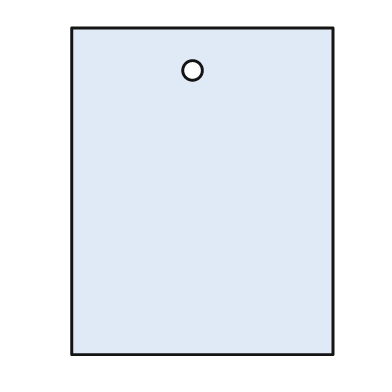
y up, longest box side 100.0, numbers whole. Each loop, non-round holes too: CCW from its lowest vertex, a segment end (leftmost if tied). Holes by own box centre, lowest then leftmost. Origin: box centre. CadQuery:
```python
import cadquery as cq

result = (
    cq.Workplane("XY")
    .moveTo(-40.0, -50.0)
    .lineTo(40.0, -50.0)
    .lineTo(40.0, 50.0)
    .lineTo(-40.0, 50.0)
    .close()
    .moveTo(-3.0, 37.0)
    .circle(3.0)
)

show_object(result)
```